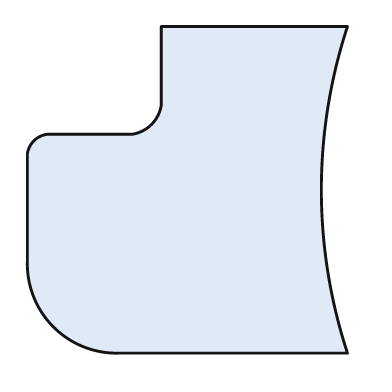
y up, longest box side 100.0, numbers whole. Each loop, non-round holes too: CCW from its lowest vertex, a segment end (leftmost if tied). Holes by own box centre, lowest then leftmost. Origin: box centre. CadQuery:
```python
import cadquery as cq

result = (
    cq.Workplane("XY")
    .moveTo(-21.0, -50.0)
    .lineTo(49.0, -50.0)
    .threePointArc((41.0, 0.0), (49.0, 50.0))
    .lineTo(-8.0, 50.0)
    .lineTo(-8.0, 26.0)
    .threePointArc((-11.0, 20.0), (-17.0, 17.0))
    .lineTo(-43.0, 17.0)
    .threePointArc((-47.0, 15.0), (-49.0, 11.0))
    .lineTo(-49.0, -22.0)
    .threePointArc((-41.0, -42.0), (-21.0, -50.0))
    .close()
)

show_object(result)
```